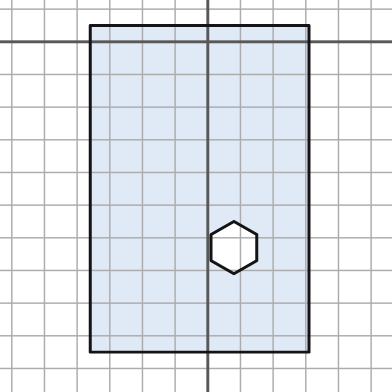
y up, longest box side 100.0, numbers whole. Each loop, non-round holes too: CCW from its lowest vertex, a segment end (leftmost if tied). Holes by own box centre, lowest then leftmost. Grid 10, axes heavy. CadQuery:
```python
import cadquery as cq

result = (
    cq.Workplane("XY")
    .moveTo(-36.0, -95.0)
    .lineTo(31.0, -95.0)
    .lineTo(31.0, 5.0)
    .lineTo(-36.0, 5.0)
    .close()
    .moveTo(8.0, -71.0)
    .lineTo(15.0, -67.0)
    .lineTo(15.0, -59.0)
    .lineTo(8.0, -55.0)
    .lineTo(1.0, -59.0)
    .lineTo(1.0, -67.0)
    .close()
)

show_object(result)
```